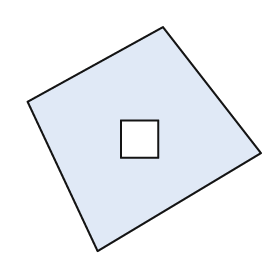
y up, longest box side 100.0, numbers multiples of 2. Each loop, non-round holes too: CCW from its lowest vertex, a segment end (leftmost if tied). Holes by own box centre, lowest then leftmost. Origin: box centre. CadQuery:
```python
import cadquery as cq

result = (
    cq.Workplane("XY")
    .moveTo(-20.0, -48.0)
    .lineTo(50.0, -6.0)
    .lineTo(8.0, 48.0)
    .lineTo(-50.0, 16.0)
    .close()
    .moveTo(-10.0, -8.0)
    .lineTo(6.0, -8.0)
    .lineTo(6.0, 8.0)
    .lineTo(-10.0, 8.0)
    .close()
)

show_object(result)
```